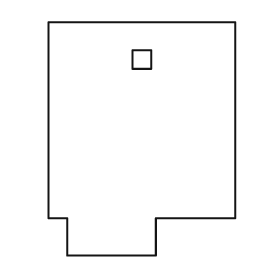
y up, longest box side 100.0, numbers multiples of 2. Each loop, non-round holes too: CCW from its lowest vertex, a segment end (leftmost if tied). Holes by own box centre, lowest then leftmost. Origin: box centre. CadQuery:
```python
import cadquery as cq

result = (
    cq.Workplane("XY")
    .moveTo(-32.0, -50.0)
    .lineTo(6.0, -50.0)
    .lineTo(6.0, -34.0)
    .lineTo(40.0, -34.0)
    .lineTo(40.0, 50.0)
    .lineTo(-40.0, 50.0)
    .lineTo(-40.0, -34.0)
    .lineTo(-32.0, -34.0)
    .close()
    .moveTo(-4.0, 30.0)
    .lineTo(4.0, 30.0)
    .lineTo(4.0, 38.0)
    .lineTo(-4.0, 38.0)
    .close()
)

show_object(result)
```